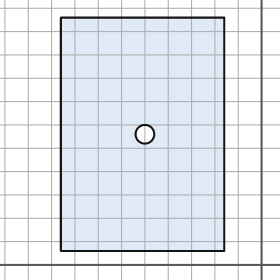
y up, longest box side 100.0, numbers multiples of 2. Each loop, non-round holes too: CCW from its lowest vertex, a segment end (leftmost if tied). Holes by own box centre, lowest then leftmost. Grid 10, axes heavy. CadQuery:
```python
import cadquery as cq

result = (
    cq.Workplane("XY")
    .moveTo(-86.0, 6.0)
    .lineTo(-16.0, 6.0)
    .lineTo(-16.0, 106.0)
    .lineTo(-86.0, 106.0)
    .close()
    .moveTo(-50.0, 56.0)
    .circle(4.0)
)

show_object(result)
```